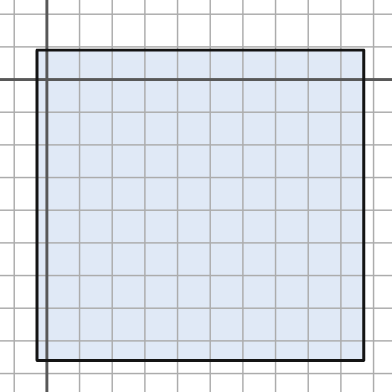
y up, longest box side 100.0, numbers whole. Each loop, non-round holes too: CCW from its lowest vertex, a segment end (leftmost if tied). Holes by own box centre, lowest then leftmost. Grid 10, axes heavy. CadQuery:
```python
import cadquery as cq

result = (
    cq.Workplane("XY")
    .moveTo(-3.0, -86.0)
    .lineTo(97.0, -86.0)
    .lineTo(97.0, 9.0)
    .lineTo(-3.0, 9.0)
    .close()
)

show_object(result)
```